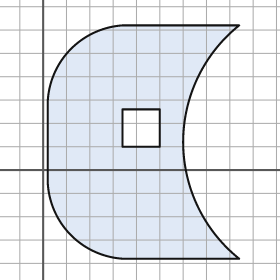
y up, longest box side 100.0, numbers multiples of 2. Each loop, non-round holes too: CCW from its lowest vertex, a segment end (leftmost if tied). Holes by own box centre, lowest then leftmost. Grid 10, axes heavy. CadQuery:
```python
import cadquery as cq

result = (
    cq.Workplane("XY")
    .moveTo(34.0, -38.0)
    .lineTo(84.0, -38.0)
    .threePointArc((60.0, 12.0), (84.0, 62.0))
    .lineTo(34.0, 62.0)
    .threePointArc((12.0, 52.0), (2.0, 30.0))
    .lineTo(2.0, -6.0)
    .threePointArc((12.0, -28.0), (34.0, -38.0))
    .close()
    .moveTo(34.0, 10.0)
    .lineTo(50.0, 10.0)
    .lineTo(50.0, 26.0)
    .lineTo(34.0, 26.0)
    .close()
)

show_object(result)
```